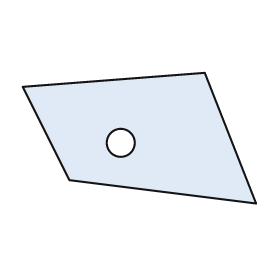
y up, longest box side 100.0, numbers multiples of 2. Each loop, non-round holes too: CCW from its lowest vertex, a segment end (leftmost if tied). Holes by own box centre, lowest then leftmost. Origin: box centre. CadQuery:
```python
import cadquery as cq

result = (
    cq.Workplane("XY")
    .moveTo(50.0, -28.0)
    .lineTo(28.0, 28.0)
    .lineTo(-50.0, 22.0)
    .lineTo(-30.0, -18.0)
    .close()
    .moveTo(-8.0, -2.0)
    .circle(6.0)
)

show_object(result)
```